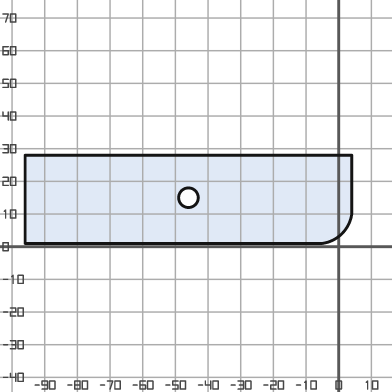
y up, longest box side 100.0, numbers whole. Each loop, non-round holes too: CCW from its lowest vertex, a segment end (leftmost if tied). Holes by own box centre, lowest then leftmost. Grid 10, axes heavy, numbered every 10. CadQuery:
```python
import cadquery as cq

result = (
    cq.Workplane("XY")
    .moveTo(-96.0, 1.0)
    .lineTo(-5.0, 1.0)
    .threePointArc((1.0, 4.0), (4.0, 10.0))
    .lineTo(4.0, 28.0)
    .lineTo(-96.0, 28.0)
    .close()
    .moveTo(-46.0, 15.0)
    .circle(3.0)
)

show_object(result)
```